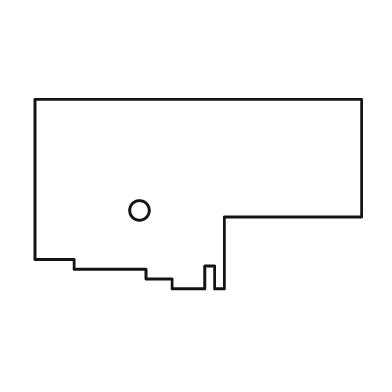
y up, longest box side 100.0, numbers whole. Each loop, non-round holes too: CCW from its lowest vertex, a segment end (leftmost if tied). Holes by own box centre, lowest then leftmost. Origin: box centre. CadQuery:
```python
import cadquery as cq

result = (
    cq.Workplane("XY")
    .moveTo(-8.0, -29.0)
    .lineTo(2.0, -29.0)
    .lineTo(2.0, -22.0)
    .lineTo(5.0, -22.0)
    .lineTo(5.0, -29.0)
    .lineTo(8.0, -29.0)
    .lineTo(8.0, -7.0)
    .lineTo(50.0, -7.0)
    .lineTo(50.0, 29.0)
    .lineTo(-50.0, 29.0)
    .lineTo(-50.0, -20.0)
    .lineTo(-38.0, -20.0)
    .lineTo(-38.0, -23.0)
    .lineTo(-16.0, -23.0)
    .lineTo(-16.0, -26.0)
    .lineTo(-8.0, -26.0)
    .close()
    .moveTo(-18.0, -5.0)
    .circle(3.0)
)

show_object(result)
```